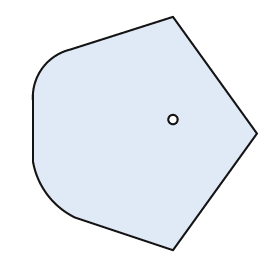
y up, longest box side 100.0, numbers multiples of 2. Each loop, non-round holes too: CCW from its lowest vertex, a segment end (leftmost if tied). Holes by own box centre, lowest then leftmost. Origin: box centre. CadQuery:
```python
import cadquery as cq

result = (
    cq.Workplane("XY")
    .moveTo(12.0, -50.0)
    .lineTo(48.0, 0.0)
    .lineTo(12.0, 50.0)
    .lineTo(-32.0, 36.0)
    .threePointArc((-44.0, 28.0), (-48.0, 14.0))
    .lineTo(-48.0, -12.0)
    .threePointArc((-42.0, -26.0), (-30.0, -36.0))
    .close()
    .moveTo(12.0, 6.0)
    .circle(2.0)
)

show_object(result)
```